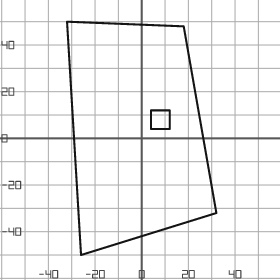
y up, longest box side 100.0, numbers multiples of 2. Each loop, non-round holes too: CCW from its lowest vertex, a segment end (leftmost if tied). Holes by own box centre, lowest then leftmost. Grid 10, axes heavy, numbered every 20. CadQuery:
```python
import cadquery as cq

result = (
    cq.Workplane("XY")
    .moveTo(-26.0, -50.0)
    .lineTo(32.0, -32.0)
    .lineTo(18.0, 48.0)
    .lineTo(-32.0, 50.0)
    .close()
    .moveTo(4.0, 4.0)
    .lineTo(12.0, 4.0)
    .lineTo(12.0, 12.0)
    .lineTo(4.0, 12.0)
    .close()
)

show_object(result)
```